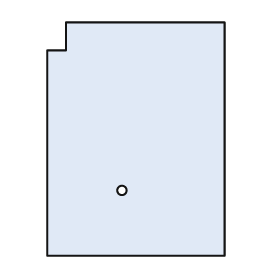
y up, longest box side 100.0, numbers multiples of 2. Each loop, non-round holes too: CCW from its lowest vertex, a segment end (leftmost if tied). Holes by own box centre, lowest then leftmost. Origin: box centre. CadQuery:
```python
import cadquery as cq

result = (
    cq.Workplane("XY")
    .moveTo(-38.0, -50.0)
    .lineTo(38.0, -50.0)
    .lineTo(38.0, 50.0)
    .lineTo(-30.0, 50.0)
    .lineTo(-30.0, 38.0)
    .lineTo(-38.0, 38.0)
    .close()
    .moveTo(-6.0, -22.0)
    .circle(2.0)
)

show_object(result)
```